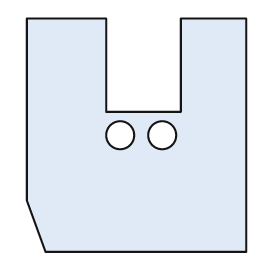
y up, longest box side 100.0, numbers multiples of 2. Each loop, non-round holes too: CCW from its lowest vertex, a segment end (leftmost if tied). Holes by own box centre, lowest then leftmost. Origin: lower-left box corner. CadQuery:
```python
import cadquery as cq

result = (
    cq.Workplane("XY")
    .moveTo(8.0, 0.0)
    .lineTo(94.0, 0.0)
    .lineTo(94.0, 100.0)
    .lineTo(66.0, 100.0)
    .lineTo(66.0, 60.0)
    .lineTo(34.0, 60.0)
    .lineTo(34.0, 100.0)
    .lineTo(0.0, 100.0)
    .lineTo(0.0, 22.0)
    .close()
    .moveTo(40.0, 50.0)
    .circle(6.0)
    .moveTo(58.0, 50.0)
    .circle(6.0)
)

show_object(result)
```